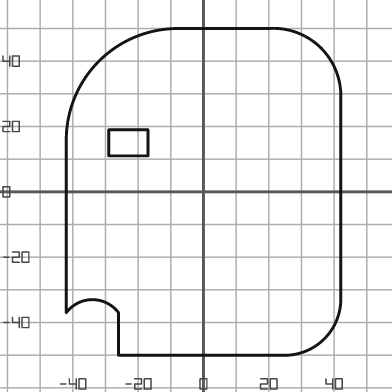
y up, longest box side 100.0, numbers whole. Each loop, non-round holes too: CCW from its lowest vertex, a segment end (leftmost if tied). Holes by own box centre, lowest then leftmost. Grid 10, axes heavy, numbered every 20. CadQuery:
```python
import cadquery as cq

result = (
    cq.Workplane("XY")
    .moveTo(-26.0, -50.0)
    .lineTo(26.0, -50.0)
    .threePointArc((37.0, -45.0), (42.0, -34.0))
    .lineTo(42.0, 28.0)
    .threePointArc((36.0, 44.0), (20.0, 50.0))
    .lineTo(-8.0, 50.0)
    .threePointArc((-32.0, 40.0), (-42.0, 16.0))
    .lineTo(-42.0, -37.0)
    .threePointArc((-34.0, -33.0), (-26.0, -37.0))
    .close()
    .moveTo(-29.0, 11.0)
    .lineTo(-17.0, 11.0)
    .lineTo(-17.0, 19.0)
    .lineTo(-29.0, 19.0)
    .close()
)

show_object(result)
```